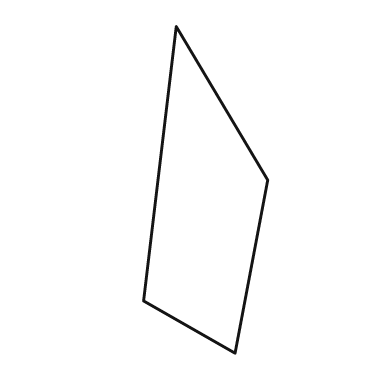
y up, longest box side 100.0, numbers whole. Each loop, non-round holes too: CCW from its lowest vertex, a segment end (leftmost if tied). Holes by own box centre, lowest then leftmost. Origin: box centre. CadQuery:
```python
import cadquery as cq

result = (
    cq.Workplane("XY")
    .moveTo(9.0, -50.0)
    .lineTo(19.0, 3.0)
    .lineTo(-9.0, 50.0)
    .lineTo(-19.0, -34.0)
    .close()
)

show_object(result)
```